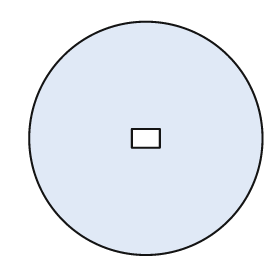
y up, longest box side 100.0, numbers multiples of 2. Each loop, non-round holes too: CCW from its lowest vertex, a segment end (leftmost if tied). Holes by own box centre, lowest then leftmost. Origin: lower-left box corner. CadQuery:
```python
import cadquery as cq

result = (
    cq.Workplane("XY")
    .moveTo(50.0, 50.0)
    .circle(50.0)
    .moveTo(44.0, 46.0)
    .lineTo(56.0, 46.0)
    .lineTo(56.0, 54.0)
    .lineTo(44.0, 54.0)
    .close()
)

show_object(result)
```